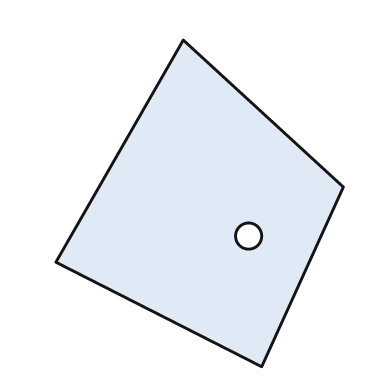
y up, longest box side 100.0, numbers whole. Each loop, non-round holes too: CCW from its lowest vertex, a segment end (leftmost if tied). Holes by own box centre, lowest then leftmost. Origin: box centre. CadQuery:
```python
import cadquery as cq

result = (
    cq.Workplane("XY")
    .moveTo(19.0, -50.0)
    .lineTo(44.0, 5.0)
    .lineTo(-5.0, 50.0)
    .lineTo(-44.0, -18.0)
    .close()
    .moveTo(15.0, -10.0)
    .circle(4.0)
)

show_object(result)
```